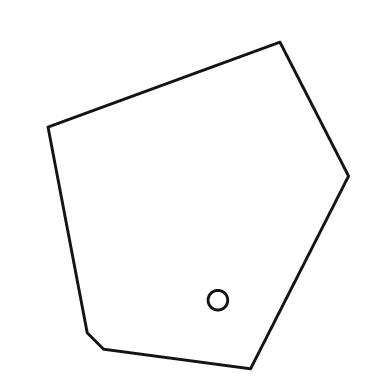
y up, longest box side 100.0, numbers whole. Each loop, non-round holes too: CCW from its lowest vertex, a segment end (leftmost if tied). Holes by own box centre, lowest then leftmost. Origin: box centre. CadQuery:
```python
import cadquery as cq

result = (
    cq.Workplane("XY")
    .moveTo(16.0, -50.0)
    .lineTo(46.0, 9.0)
    .lineTo(25.0, 50.0)
    .lineTo(-46.0, 24.0)
    .lineTo(-34.0, -39.0)
    .lineTo(-29.0, -44.0)
    .close()
    .moveTo(6.0, -29.0)
    .circle(3.0)
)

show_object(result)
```